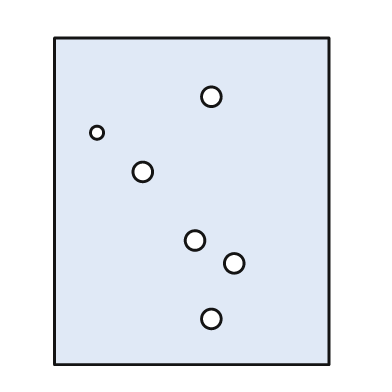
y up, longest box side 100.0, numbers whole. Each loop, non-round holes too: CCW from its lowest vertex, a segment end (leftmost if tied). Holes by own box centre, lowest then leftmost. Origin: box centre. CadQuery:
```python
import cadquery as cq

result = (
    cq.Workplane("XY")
    .moveTo(-42.0, -50.0)
    .lineTo(42.0, -50.0)
    .lineTo(42.0, 50.0)
    .lineTo(-42.0, 50.0)
    .close()
    .moveTo(6.0, -36.0)
    .circle(3.0)
    .moveTo(13.0, -19.0)
    .circle(3.0)
    .moveTo(1.0, -12.0)
    .circle(3.0)
    .moveTo(-15.0, 9.0)
    .circle(3.0)
    .moveTo(-29.0, 21.0)
    .circle(2.0)
    .moveTo(6.0, 32.0)
    .circle(3.0)
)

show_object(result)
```